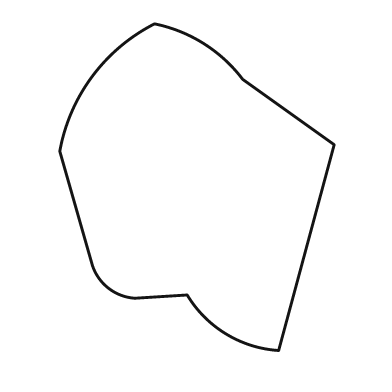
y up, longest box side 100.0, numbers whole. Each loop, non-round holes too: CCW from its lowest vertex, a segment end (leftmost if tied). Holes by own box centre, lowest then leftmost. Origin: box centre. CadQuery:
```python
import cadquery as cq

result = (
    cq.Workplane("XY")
    .moveTo(25.0, -50.0)
    .lineTo(42.0, 13.0)
    .lineTo(14.0, 33.0)
    .threePointArc((2.0, 44.0), (-13.0, 50.0))
    .threePointArc((-32.0, 34.0), (-42.0, 11.0))
    .lineTo(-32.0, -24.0)
    .threePointArc((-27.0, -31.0), (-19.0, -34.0))
    .lineTo(-3.0, -33.0)
    .threePointArc((9.0, -45.0), (25.0, -50.0))
    .close()
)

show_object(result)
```